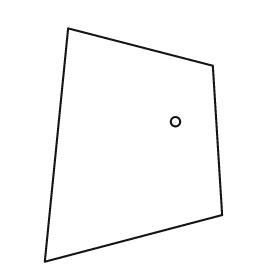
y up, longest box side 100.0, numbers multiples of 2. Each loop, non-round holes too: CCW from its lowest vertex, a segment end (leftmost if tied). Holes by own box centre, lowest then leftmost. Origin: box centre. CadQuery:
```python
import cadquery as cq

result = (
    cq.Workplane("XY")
    .moveTo(-38.0, -50.0)
    .lineTo(38.0, -30.0)
    .lineTo(34.0, 34.0)
    .lineTo(-28.0, 50.0)
    .close()
    .moveTo(18.0, 10.0)
    .circle(2.0)
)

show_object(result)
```